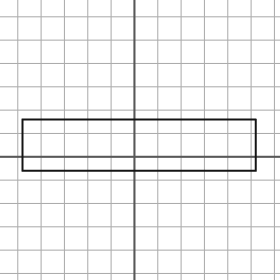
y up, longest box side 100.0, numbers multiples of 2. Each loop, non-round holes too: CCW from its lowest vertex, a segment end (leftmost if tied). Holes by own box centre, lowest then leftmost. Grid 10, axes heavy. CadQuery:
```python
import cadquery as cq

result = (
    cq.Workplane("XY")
    .moveTo(-48.0, -6.0)
    .lineTo(52.0, -6.0)
    .lineTo(52.0, 16.0)
    .lineTo(-48.0, 16.0)
    .close()
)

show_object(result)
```